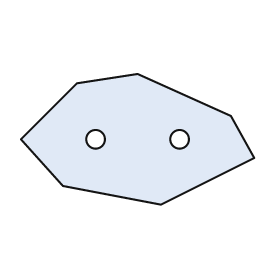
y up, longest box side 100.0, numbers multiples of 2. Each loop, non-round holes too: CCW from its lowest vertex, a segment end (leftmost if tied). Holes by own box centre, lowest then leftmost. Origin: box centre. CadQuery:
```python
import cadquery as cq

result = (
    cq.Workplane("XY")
    .moveTo(10.0, -28.0)
    .lineTo(50.0, -8.0)
    .lineTo(40.0, 10.0)
    .lineTo(0.0, 28.0)
    .lineTo(-26.0, 24.0)
    .lineTo(-50.0, 0.0)
    .lineTo(-32.0, -20.0)
    .close()
    .moveTo(-18.0, 0.0)
    .circle(4.0)
    .moveTo(18.0, 0.0)
    .circle(4.0)
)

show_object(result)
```